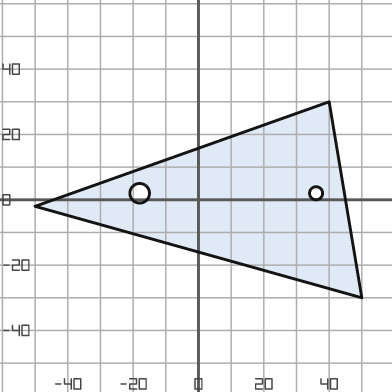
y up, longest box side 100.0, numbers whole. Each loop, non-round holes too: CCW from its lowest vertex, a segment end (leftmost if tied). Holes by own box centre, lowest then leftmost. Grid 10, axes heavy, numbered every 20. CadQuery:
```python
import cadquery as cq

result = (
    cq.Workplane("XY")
    .moveTo(50.0, -30.0)
    .lineTo(40.0, 30.0)
    .lineTo(-50.0, -2.0)
    .close()
    .moveTo(-18.0, 2.0)
    .circle(3.0)
    .moveTo(36.0, 2.0)
    .circle(2.0)
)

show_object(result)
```